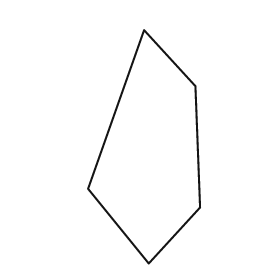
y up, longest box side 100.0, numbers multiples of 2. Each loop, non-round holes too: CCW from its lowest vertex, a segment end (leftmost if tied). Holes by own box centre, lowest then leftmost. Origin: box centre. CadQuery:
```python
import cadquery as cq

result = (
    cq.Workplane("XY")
    .moveTo(2.0, -50.0)
    .lineTo(24.0, -26.0)
    .lineTo(22.0, 26.0)
    .lineTo(0.0, 50.0)
    .lineTo(-24.0, -18.0)
    .close()
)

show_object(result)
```